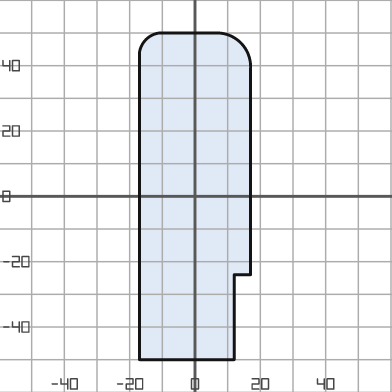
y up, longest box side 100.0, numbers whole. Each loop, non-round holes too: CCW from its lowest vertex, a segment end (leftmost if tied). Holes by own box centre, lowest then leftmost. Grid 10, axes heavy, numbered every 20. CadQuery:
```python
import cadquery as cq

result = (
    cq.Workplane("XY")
    .moveTo(-17.0, -50.0)
    .lineTo(12.0, -50.0)
    .lineTo(12.0, -24.0)
    .lineTo(17.0, -24.0)
    .lineTo(17.0, 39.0)
    .threePointArc((14.0, 47.0), (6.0, 50.0))
    .lineTo(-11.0, 50.0)
    .threePointArc((-15.0, 48.0), (-17.0, 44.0))
    .close()
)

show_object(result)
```